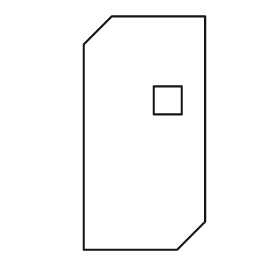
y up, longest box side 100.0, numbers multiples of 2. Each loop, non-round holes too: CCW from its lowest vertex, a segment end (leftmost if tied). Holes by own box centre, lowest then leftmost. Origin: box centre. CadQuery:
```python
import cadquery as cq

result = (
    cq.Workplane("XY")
    .moveTo(-26.0, -50.0)
    .lineTo(14.0, -50.0)
    .lineTo(26.0, -38.0)
    .lineTo(26.0, 50.0)
    .lineTo(-14.0, 50.0)
    .lineTo(-26.0, 38.0)
    .close()
    .moveTo(4.0, 8.0)
    .lineTo(16.0, 8.0)
    .lineTo(16.0, 20.0)
    .lineTo(4.0, 20.0)
    .close()
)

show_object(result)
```